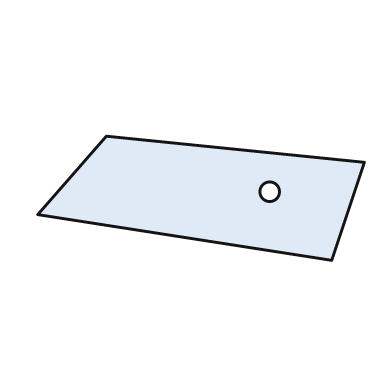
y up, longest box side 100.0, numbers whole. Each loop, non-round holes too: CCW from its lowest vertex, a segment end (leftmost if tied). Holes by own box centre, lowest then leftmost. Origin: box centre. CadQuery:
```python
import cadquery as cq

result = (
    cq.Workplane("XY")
    .moveTo(40.0, -19.0)
    .lineTo(50.0, 11.0)
    .lineTo(-29.0, 19.0)
    .lineTo(-50.0, -5.0)
    .close()
    .moveTo(21.0, 2.0)
    .circle(3.0)
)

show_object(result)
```